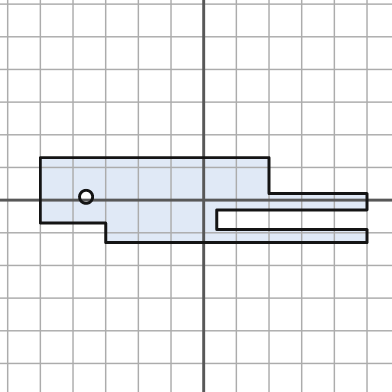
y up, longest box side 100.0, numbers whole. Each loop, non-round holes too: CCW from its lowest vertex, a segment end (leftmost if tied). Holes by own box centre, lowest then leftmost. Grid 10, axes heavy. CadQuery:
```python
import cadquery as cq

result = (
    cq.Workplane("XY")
    .moveTo(-30.0, -13.0)
    .lineTo(50.0, -13.0)
    .lineTo(50.0, -9.0)
    .lineTo(4.0, -9.0)
    .lineTo(4.0, -3.0)
    .lineTo(50.0, -3.0)
    .lineTo(50.0, 2.0)
    .lineTo(20.0, 2.0)
    .lineTo(20.0, 13.0)
    .lineTo(-50.0, 13.0)
    .lineTo(-50.0, -7.0)
    .lineTo(-30.0, -7.0)
    .close()
    .moveTo(-36.0, 1.0)
    .circle(2.0)
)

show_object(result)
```